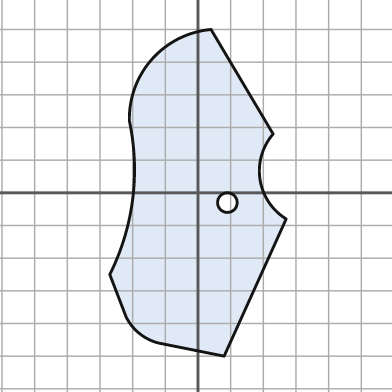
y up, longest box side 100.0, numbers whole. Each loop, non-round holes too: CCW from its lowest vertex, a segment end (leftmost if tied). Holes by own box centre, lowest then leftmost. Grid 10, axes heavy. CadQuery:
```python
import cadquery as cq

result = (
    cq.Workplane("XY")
    .moveTo(8.0, -50.0)
    .lineTo(27.0, -8.0)
    .threePointArc((19.0, 4.0), (23.0, 18.0))
    .lineTo(4.0, 50.0)
    .threePointArc((-14.0, 41.0), (-21.0, 22.0))
    .threePointArc((-20.0, -2.0), (-27.0, -25.0))
    .lineTo(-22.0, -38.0)
    .threePointArc((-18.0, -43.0), (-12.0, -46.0))
    .close()
    .moveTo(9.0, -3.0)
    .circle(3.0)
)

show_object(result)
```